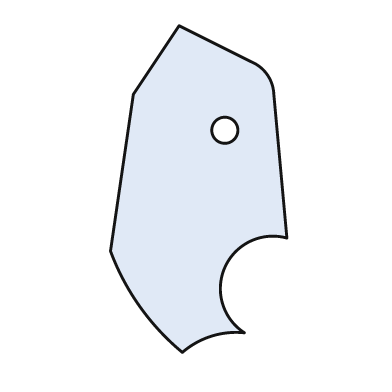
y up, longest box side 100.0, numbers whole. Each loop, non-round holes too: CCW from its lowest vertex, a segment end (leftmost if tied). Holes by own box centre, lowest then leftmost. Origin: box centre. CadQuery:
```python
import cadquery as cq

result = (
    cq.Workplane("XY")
    .moveTo(-5.0, -50.0)
    .threePointArc((4.0, -45.0), (14.0, -44.0))
    .threePointArc((8.0, -24.0), (27.0, -15.0))
    .lineTo(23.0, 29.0)
    .threePointArc((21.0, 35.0), (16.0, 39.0))
    .lineTo(-6.0, 50.0)
    .lineTo(-20.0, 29.0)
    .lineTo(-27.0, -19.0)
    .threePointArc((-18.0, -36.0), (-5.0, -50.0))
    .close()
    .moveTo(8.0, 18.0)
    .circle(4.0)
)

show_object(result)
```